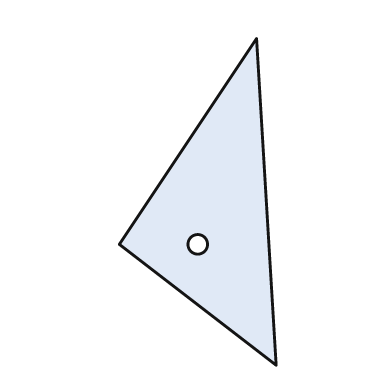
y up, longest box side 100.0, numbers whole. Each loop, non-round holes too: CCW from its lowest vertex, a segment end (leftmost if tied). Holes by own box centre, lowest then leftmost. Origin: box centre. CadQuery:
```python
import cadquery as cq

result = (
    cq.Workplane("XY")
    .moveTo(24.0, -50.0)
    .lineTo(18.0, 50.0)
    .lineTo(-24.0, -13.0)
    .close()
    .moveTo(0.0, -13.0)
    .circle(3.0)
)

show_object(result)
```